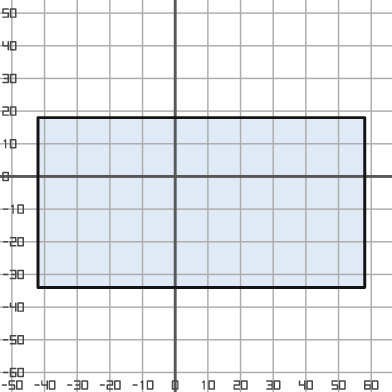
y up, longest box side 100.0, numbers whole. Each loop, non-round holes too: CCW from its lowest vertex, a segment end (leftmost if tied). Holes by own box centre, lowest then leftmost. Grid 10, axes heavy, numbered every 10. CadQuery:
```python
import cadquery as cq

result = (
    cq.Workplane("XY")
    .moveTo(-42.0, -34.0)
    .lineTo(58.0, -34.0)
    .lineTo(58.0, 18.0)
    .lineTo(-42.0, 18.0)
    .close()
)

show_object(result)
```